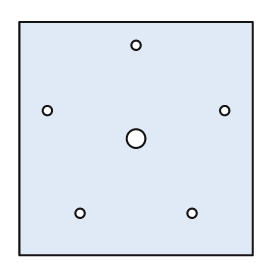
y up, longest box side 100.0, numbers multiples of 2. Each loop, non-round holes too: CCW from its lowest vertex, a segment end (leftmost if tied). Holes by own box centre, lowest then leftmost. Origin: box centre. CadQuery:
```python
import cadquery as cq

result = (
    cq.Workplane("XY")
    .moveTo(-50.0, -50.0)
    .lineTo(50.0, -50.0)
    .lineTo(50.0, 50.0)
    .lineTo(-50.0, 50.0)
    .close()
    .moveTo(-24.0, -32.0)
    .circle(2.0)
    .moveTo(24.0, -32.0)
    .circle(2.0)
    .moveTo(0.0, 0.0)
    .circle(4.0)
    .moveTo(-38.0, 12.0)
    .circle(2.0)
    .moveTo(38.0, 12.0)
    .circle(2.0)
    .moveTo(0.0, 40.0)
    .circle(2.0)
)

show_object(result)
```